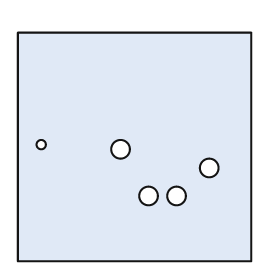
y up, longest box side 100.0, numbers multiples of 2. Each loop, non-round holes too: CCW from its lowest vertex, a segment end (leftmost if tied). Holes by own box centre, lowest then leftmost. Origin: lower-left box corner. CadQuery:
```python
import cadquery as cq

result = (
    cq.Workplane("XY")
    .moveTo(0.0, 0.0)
    .lineTo(100.0, 0.0)
    .lineTo(100.0, 98.0)
    .lineTo(0.0, 98.0)
    .close()
    .moveTo(56.0, 28.0)
    .circle(4.0)
    .moveTo(68.0, 28.0)
    .circle(4.0)
    .moveTo(82.0, 40.0)
    .circle(4.0)
    .moveTo(44.0, 48.0)
    .circle(4.0)
    .moveTo(10.0, 50.0)
    .circle(2.0)
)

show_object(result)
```